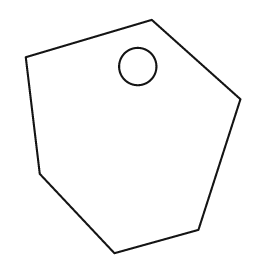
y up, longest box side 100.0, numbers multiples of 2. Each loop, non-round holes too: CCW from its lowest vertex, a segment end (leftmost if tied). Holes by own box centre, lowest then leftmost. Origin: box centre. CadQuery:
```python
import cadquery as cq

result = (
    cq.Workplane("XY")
    .moveTo(-8.0, -50.0)
    .lineTo(28.0, -40.0)
    .lineTo(46.0, 16.0)
    .lineTo(8.0, 50.0)
    .lineTo(-46.0, 34.0)
    .lineTo(-40.0, -16.0)
    .close()
    .moveTo(2.0, 30.0)
    .circle(8.0)
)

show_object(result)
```